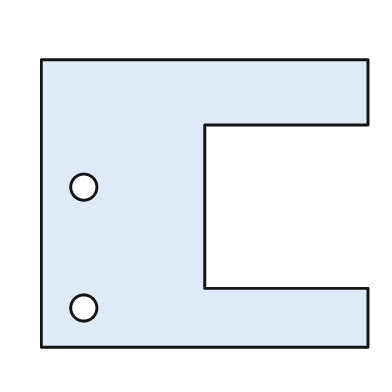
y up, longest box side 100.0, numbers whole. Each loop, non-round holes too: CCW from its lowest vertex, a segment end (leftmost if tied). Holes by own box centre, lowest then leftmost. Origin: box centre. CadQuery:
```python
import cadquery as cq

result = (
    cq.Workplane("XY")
    .moveTo(-50.0, -44.0)
    .lineTo(50.0, -44.0)
    .lineTo(50.0, -26.0)
    .lineTo(0.0, -26.0)
    .lineTo(0.0, 24.0)
    .lineTo(50.0, 24.0)
    .lineTo(50.0, 44.0)
    .lineTo(-50.0, 44.0)
    .close()
    .moveTo(-37.0, -32.0)
    .circle(4.0)
    .moveTo(-37.0, 5.0)
    .circle(4.0)
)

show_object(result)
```